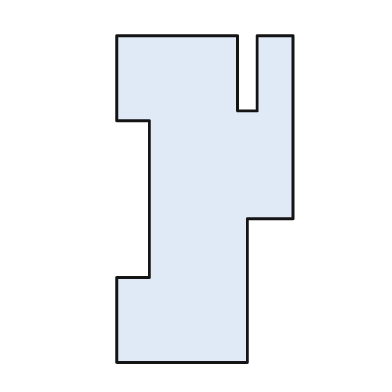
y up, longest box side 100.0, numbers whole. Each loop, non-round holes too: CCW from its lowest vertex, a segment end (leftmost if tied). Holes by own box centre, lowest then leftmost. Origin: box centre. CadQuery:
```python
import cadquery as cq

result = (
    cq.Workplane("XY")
    .moveTo(-27.0, -50.0)
    .lineTo(13.0, -50.0)
    .lineTo(13.0, -6.0)
    .lineTo(27.0, -6.0)
    .lineTo(27.0, 50.0)
    .lineTo(16.0, 50.0)
    .lineTo(16.0, 27.0)
    .lineTo(10.0, 27.0)
    .lineTo(10.0, 50.0)
    .lineTo(-27.0, 50.0)
    .lineTo(-27.0, 24.0)
    .lineTo(-17.0, 24.0)
    .lineTo(-17.0, -24.0)
    .lineTo(-27.0, -24.0)
    .close()
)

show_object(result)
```